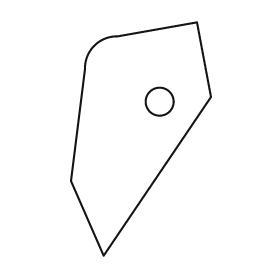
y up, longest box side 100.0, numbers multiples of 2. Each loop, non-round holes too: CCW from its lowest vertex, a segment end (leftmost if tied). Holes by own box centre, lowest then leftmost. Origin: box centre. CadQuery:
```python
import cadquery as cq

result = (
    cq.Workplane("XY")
    .moveTo(-16.0, -50.0)
    .lineTo(30.0, 18.0)
    .lineTo(24.0, 50.0)
    .lineTo(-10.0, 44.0)
    .threePointArc((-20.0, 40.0), (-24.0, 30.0))
    .lineTo(-30.0, -18.0)
    .close()
    .moveTo(8.0, 16.0)
    .circle(6.0)
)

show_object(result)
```